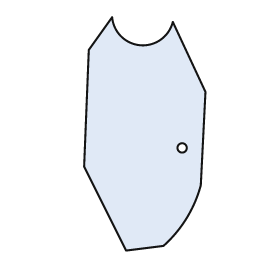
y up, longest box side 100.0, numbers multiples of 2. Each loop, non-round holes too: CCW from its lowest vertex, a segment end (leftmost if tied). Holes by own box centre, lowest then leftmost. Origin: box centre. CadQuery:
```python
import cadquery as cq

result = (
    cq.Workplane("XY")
    .moveTo(-8.0, -50.0)
    .lineTo(8.0, -48.0)
    .threePointArc((18.0, -36.0), (24.0, -22.0))
    .lineTo(26.0, 18.0)
    .lineTo(12.0, 48.0)
    .threePointArc((-2.0, 38.0), (-14.0, 50.0))
    .lineTo(-24.0, 36.0)
    .lineTo(-26.0, -14.0)
    .close()
    .moveTo(16.0, -6.0)
    .circle(2.0)
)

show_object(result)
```